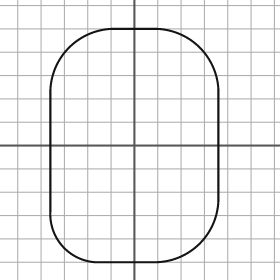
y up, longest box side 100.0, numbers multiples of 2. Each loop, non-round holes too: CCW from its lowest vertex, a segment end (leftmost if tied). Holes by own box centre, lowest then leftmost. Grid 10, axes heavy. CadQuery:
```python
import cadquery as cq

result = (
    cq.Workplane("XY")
    .moveTo(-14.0, -50.0)
    .lineTo(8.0, -50.0)
    .threePointArc((28.0, -42.0), (36.0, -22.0))
    .lineTo(36.0, 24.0)
    .threePointArc((28.0, 42.0), (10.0, 50.0))
    .lineTo(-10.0, 50.0)
    .threePointArc((-28.0, 42.0), (-36.0, 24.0))
    .lineTo(-36.0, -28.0)
    .threePointArc((-30.0, -44.0), (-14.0, -50.0))
    .close()
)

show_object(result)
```